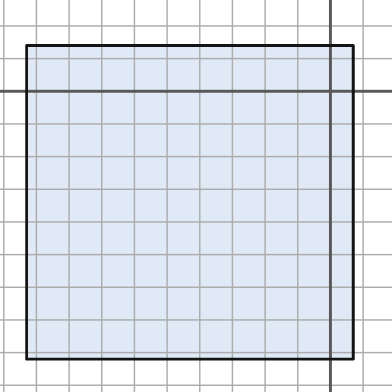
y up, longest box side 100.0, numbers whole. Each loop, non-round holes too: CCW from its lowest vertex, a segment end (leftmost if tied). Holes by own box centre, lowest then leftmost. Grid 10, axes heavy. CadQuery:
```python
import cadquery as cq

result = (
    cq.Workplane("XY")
    .moveTo(-93.0, -82.0)
    .lineTo(7.0, -82.0)
    .lineTo(7.0, 14.0)
    .lineTo(-93.0, 14.0)
    .close()
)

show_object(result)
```